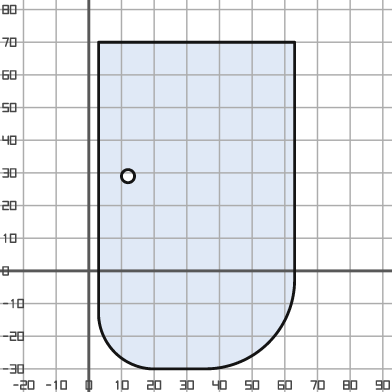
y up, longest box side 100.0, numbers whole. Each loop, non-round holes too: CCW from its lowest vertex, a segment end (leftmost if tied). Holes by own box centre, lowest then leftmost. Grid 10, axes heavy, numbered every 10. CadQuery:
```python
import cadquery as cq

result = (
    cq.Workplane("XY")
    .moveTo(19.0, -30.0)
    .lineTo(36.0, -30.0)
    .threePointArc((55.0, -22.0), (63.0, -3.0))
    .lineTo(63.0, 70.0)
    .lineTo(3.0, 70.0)
    .lineTo(3.0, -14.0)
    .threePointArc((8.0, -25.0), (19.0, -30.0))
    .close()
    .moveTo(12.0, 29.0)
    .circle(2.0)
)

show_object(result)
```